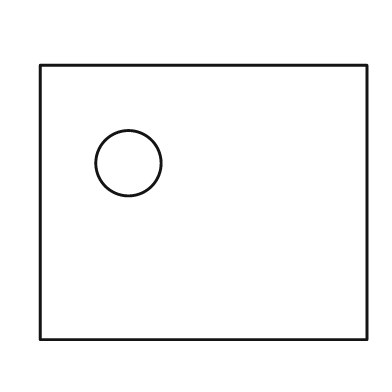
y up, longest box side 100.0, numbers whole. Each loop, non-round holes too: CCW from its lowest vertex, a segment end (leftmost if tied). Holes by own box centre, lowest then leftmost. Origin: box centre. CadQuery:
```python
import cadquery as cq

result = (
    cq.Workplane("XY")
    .moveTo(-50.0, -42.0)
    .lineTo(50.0, -42.0)
    .lineTo(50.0, 42.0)
    .lineTo(-50.0, 42.0)
    .close()
    .moveTo(-23.0, 12.0)
    .circle(10.0)
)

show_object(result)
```